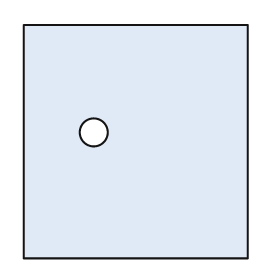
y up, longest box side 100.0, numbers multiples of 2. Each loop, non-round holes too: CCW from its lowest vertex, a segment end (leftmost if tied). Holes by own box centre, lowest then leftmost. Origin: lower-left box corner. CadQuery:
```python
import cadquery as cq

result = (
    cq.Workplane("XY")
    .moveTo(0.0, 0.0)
    .lineTo(96.0, 0.0)
    .lineTo(96.0, 100.0)
    .lineTo(0.0, 100.0)
    .close()
    .moveTo(30.0, 54.0)
    .circle(6.0)
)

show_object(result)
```